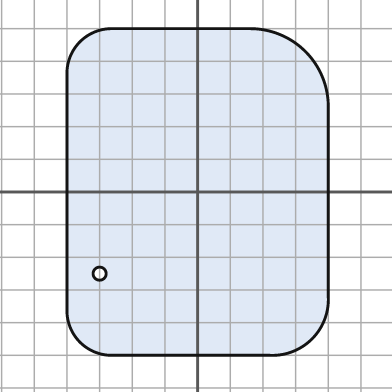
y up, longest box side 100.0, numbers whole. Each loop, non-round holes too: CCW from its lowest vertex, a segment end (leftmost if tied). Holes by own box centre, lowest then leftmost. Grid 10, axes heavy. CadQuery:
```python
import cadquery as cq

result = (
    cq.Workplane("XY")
    .moveTo(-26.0, -50.0)
    .lineTo(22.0, -50.0)
    .threePointArc((35.0, -45.0), (40.0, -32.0))
    .lineTo(40.0, 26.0)
    .threePointArc((33.0, 43.0), (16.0, 50.0))
    .lineTo(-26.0, 50.0)
    .threePointArc((-36.0, 46.0), (-40.0, 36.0))
    .lineTo(-40.0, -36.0)
    .threePointArc((-36.0, -46.0), (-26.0, -50.0))
    .close()
    .moveTo(-30.0, -25.0)
    .circle(2.0)
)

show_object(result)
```